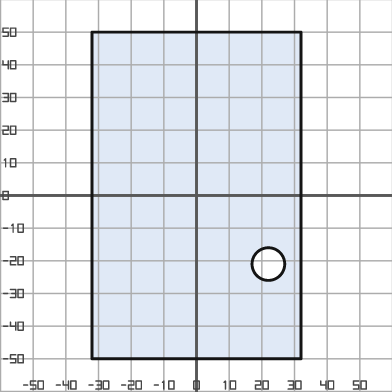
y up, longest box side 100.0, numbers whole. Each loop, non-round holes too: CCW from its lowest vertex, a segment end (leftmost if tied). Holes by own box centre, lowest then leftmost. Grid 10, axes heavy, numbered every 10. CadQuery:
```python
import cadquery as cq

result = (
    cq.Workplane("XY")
    .moveTo(-32.0, -50.0)
    .lineTo(32.0, -50.0)
    .lineTo(32.0, 50.0)
    .lineTo(-32.0, 50.0)
    .close()
    .moveTo(22.0, -21.0)
    .circle(5.0)
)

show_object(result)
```